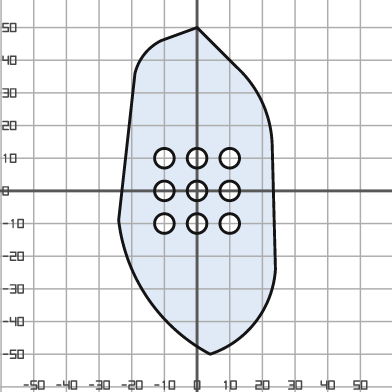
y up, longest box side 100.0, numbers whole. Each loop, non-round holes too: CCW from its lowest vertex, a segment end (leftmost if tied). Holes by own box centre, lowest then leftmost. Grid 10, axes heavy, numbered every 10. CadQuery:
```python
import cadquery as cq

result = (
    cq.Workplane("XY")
    .moveTo(4.0, -50.0)
    .threePointArc((18.0, -40.0), (24.0, -24.0))
    .lineTo(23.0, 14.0)
    .threePointArc((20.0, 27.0), (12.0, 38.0))
    .lineTo(0.0, 50.0)
    .lineTo(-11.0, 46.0)
    .threePointArc((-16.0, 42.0), (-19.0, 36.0))
    .lineTo(-24.0, -9.0)
    .threePointArc((-15.0, -33.0), (4.0, -50.0))
    .close()
    .moveTo(-10.0, -10.0)
    .circle(3.0)
    .moveTo(0.0, -10.0)
    .circle(3.0)
    .moveTo(10.0, -10.0)
    .circle(3.0)
    .moveTo(-10.0, 0.0)
    .circle(3.0)
    .moveTo(0.0, 0.0)
    .circle(3.0)
    .moveTo(10.0, 0.0)
    .circle(3.0)
    .moveTo(-10.0, 10.0)
    .circle(3.0)
    .moveTo(0.0, 10.0)
    .circle(3.0)
    .moveTo(10.0, 10.0)
    .circle(3.0)
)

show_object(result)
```